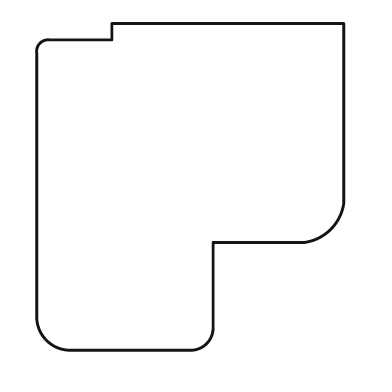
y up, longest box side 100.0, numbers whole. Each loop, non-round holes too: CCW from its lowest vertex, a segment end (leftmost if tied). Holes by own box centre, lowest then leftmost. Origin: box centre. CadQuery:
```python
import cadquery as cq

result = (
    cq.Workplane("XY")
    .moveTo(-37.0, -50.0)
    .lineTo(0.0, -50.0)
    .threePointArc((5.0, -48.0), (7.0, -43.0))
    .lineTo(7.0, -17.0)
    .lineTo(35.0, -17.0)
    .threePointArc((43.0, -13.0), (47.0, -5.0))
    .lineTo(47.0, 50.0)
    .lineTo(-24.0, 50.0)
    .lineTo(-24.0, 45.0)
    .lineTo(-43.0, 45.0)
    .threePointArc((-46.0, 44.0), (-47.0, 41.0))
    .lineTo(-47.0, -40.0)
    .threePointArc((-44.0, -47.0), (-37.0, -50.0))
    .close()
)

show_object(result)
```